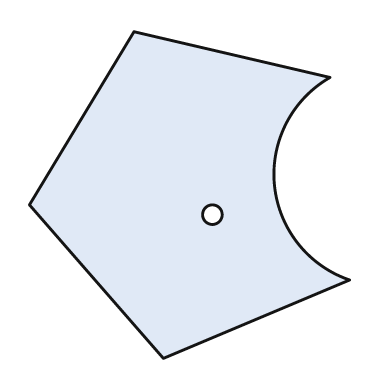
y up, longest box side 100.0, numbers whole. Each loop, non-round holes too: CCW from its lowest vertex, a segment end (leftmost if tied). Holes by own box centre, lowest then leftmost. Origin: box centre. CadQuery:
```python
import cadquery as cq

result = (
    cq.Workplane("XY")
    .moveTo(-8.0, -50.0)
    .lineTo(49.0, -26.0)
    .threePointArc((26.0, 3.0), (43.0, 36.0))
    .lineTo(-17.0, 50.0)
    .lineTo(-49.0, -3.0)
    .close()
    .moveTo(7.0, -6.0)
    .circle(3.0)
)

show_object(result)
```